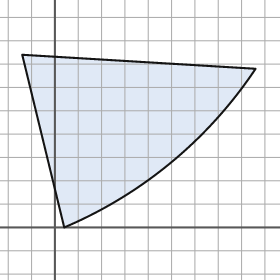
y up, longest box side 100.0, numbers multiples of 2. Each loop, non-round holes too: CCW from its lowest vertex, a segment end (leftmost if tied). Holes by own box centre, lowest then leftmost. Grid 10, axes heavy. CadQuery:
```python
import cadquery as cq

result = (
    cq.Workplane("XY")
    .moveTo(4.0, 0.0)
    .threePointArc((50.0, 28.0), (86.0, 68.0))
    .lineTo(-14.0, 74.0)
    .close()
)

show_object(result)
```